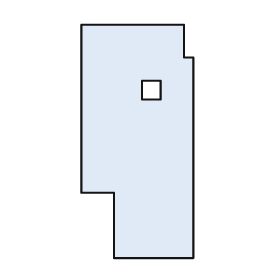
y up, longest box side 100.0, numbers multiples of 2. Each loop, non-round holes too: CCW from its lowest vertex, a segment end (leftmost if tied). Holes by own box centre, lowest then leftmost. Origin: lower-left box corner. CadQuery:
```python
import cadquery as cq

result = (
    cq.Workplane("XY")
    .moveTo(14.0, 0.0)
    .lineTo(48.0, 0.0)
    .lineTo(48.0, 86.0)
    .lineTo(44.0, 86.0)
    .lineTo(44.0, 100.0)
    .lineTo(0.0, 100.0)
    .lineTo(0.0, 28.0)
    .lineTo(14.0, 28.0)
    .close()
    .moveTo(26.0, 68.0)
    .lineTo(34.0, 68.0)
    .lineTo(34.0, 76.0)
    .lineTo(26.0, 76.0)
    .close()
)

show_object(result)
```